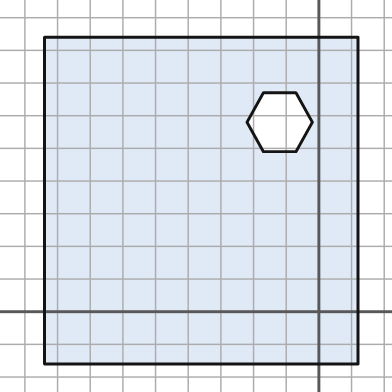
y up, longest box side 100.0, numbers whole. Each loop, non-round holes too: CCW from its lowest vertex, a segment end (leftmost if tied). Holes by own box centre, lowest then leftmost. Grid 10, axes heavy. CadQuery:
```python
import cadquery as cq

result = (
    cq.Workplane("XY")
    .moveTo(-84.0, -16.0)
    .lineTo(12.0, -16.0)
    .lineTo(12.0, 84.0)
    .lineTo(-84.0, 84.0)
    .close()
    .moveTo(-17.0, 49.0)
    .lineTo(-7.0, 49.0)
    .lineTo(-2.0, 58.0)
    .lineTo(-7.0, 67.0)
    .lineTo(-17.0, 67.0)
    .lineTo(-22.0, 58.0)
    .close()
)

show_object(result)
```